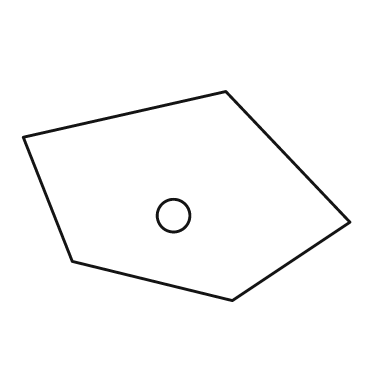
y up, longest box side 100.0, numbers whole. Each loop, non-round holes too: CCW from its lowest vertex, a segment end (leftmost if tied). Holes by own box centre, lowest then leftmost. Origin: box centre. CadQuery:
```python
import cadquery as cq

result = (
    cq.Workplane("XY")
    .moveTo(14.0, -32.0)
    .lineTo(50.0, -8.0)
    .lineTo(12.0, 32.0)
    .lineTo(-50.0, 18.0)
    .lineTo(-35.0, -20.0)
    .close()
    .moveTo(-4.0, -6.0)
    .circle(5.0)
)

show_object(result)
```